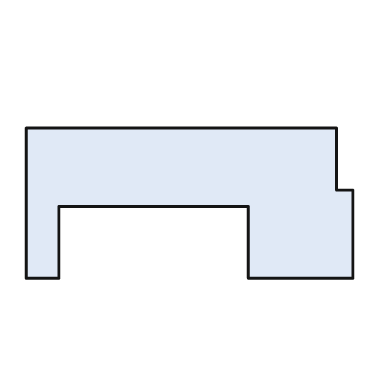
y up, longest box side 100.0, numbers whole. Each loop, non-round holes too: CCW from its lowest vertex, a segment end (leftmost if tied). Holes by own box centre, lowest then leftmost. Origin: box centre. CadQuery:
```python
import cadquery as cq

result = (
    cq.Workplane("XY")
    .moveTo(-50.0, -23.0)
    .lineTo(-40.0, -23.0)
    .lineTo(-40.0, -1.0)
    .lineTo(18.0, -1.0)
    .lineTo(18.0, -23.0)
    .lineTo(50.0, -23.0)
    .lineTo(50.0, 4.0)
    .lineTo(45.0, 4.0)
    .lineTo(45.0, 23.0)
    .lineTo(-50.0, 23.0)
    .close()
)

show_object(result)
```